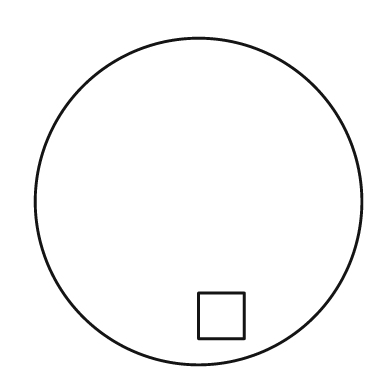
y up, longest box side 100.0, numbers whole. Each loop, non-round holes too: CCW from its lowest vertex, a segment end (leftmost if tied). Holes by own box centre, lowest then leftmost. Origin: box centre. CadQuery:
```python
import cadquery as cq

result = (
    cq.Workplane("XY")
    .moveTo(0.0, 0.0)
    .circle(50.0)
    .moveTo(0.0, -42.0)
    .lineTo(14.0, -42.0)
    .lineTo(14.0, -28.0)
    .lineTo(0.0, -28.0)
    .close()
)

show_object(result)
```